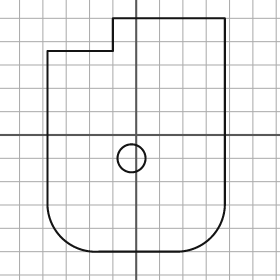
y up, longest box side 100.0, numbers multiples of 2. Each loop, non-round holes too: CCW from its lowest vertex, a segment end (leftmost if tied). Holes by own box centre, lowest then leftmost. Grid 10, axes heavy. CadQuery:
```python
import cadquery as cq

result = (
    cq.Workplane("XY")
    .moveTo(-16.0, -50.0)
    .lineTo(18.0, -50.0)
    .threePointArc((32.0, -44.0), (38.0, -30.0))
    .lineTo(38.0, 50.0)
    .lineTo(-10.0, 50.0)
    .lineTo(-10.0, 36.0)
    .lineTo(-38.0, 36.0)
    .lineTo(-38.0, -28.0)
    .threePointArc((-32.0, -44.0), (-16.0, -50.0))
    .close()
    .moveTo(-2.0, -10.0)
    .circle(6.0)
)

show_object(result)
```